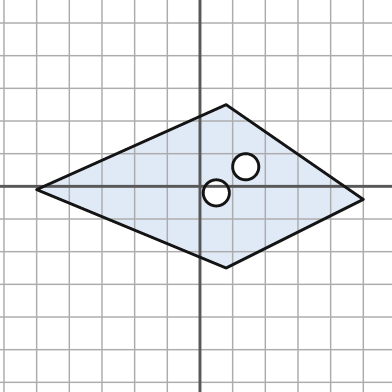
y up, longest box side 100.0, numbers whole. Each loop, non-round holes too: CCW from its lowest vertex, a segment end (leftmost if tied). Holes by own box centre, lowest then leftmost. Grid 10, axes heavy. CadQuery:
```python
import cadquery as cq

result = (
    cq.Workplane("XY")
    .moveTo(8.0, -25.0)
    .lineTo(50.0, -4.0)
    .lineTo(8.0, 25.0)
    .lineTo(-50.0, -1.0)
    .close()
    .moveTo(5.0, -2.0)
    .circle(4.0)
    .moveTo(14.0, 6.0)
    .circle(4.0)
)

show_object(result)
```